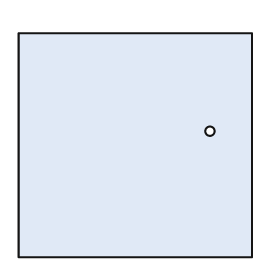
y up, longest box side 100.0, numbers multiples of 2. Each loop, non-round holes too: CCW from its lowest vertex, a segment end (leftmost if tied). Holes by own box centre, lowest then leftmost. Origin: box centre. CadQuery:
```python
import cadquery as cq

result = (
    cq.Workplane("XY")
    .moveTo(-50.0, -48.0)
    .lineTo(50.0, -48.0)
    .lineTo(50.0, 48.0)
    .lineTo(-50.0, 48.0)
    .close()
    .moveTo(32.0, 6.0)
    .circle(2.0)
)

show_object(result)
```